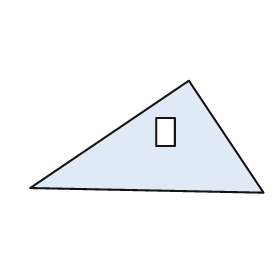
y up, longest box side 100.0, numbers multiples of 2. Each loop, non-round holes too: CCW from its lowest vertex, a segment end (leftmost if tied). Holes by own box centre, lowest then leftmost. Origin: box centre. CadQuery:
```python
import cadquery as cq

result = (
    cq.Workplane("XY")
    .moveTo(50.0, -24.0)
    .lineTo(18.0, 24.0)
    .lineTo(-50.0, -22.0)
    .close()
    .moveTo(4.0, -4.0)
    .lineTo(12.0, -4.0)
    .lineTo(12.0, 8.0)
    .lineTo(4.0, 8.0)
    .close()
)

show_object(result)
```